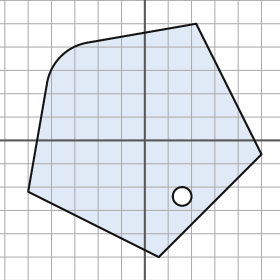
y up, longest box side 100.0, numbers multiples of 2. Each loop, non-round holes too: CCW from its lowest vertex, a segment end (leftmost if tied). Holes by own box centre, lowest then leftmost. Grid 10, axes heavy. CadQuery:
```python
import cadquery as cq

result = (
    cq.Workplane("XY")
    .moveTo(6.0, -50.0)
    .lineTo(50.0, -6.0)
    .lineTo(22.0, 50.0)
    .lineTo(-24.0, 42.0)
    .threePointArc((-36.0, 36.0), (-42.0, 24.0))
    .lineTo(-50.0, -22.0)
    .close()
    .moveTo(16.0, -24.0)
    .circle(4.0)
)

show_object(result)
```